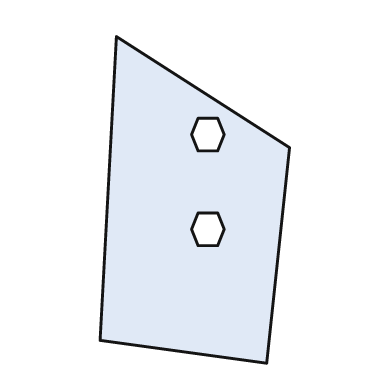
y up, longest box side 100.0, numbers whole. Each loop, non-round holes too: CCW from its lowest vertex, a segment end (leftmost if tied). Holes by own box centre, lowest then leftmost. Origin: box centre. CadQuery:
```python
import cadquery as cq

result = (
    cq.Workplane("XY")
    .moveTo(22.0, -50.0)
    .lineTo(29.0, 16.0)
    .lineTo(-24.0, 50.0)
    .lineTo(-29.0, -43.0)
    .close()
    .moveTo(1.0, -14.0)
    .lineTo(7.0, -14.0)
    .lineTo(9.0, -9.0)
    .lineTo(7.0, -4.0)
    .lineTo(1.0, -4.0)
    .lineTo(-1.0, -9.0)
    .close()
    .moveTo(1.0, 15.0)
    .lineTo(7.0, 15.0)
    .lineTo(9.0, 20.0)
    .lineTo(7.0, 25.0)
    .lineTo(1.0, 25.0)
    .lineTo(-1.0, 20.0)
    .close()
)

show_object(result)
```